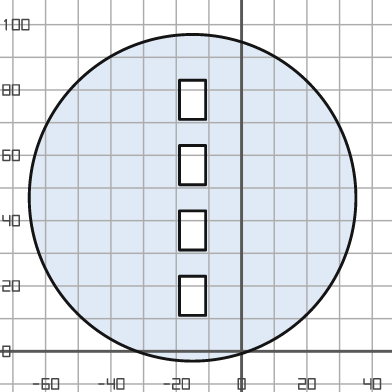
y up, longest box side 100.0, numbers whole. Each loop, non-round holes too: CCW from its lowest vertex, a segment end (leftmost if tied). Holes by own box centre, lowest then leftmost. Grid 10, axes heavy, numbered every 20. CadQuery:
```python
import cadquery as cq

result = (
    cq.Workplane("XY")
    .moveTo(-15.0, 47.0)
    .circle(50.0)
    .moveTo(-19.0, 11.0)
    .lineTo(-11.0, 11.0)
    .lineTo(-11.0, 23.0)
    .lineTo(-19.0, 23.0)
    .close()
    .moveTo(-19.0, 31.0)
    .lineTo(-11.0, 31.0)
    .lineTo(-11.0, 43.0)
    .lineTo(-19.0, 43.0)
    .close()
    .moveTo(-19.0, 51.0)
    .lineTo(-11.0, 51.0)
    .lineTo(-11.0, 63.0)
    .lineTo(-19.0, 63.0)
    .close()
    .moveTo(-19.0, 71.0)
    .lineTo(-11.0, 71.0)
    .lineTo(-11.0, 83.0)
    .lineTo(-19.0, 83.0)
    .close()
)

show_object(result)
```